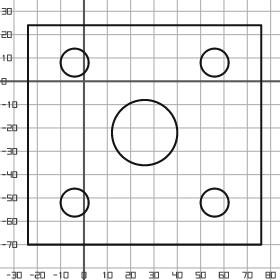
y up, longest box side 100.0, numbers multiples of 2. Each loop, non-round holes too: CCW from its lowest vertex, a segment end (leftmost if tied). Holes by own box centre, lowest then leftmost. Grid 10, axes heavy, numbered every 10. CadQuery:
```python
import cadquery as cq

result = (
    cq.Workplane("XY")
    .moveTo(-24.0, -70.0)
    .lineTo(76.0, -70.0)
    .lineTo(76.0, 24.0)
    .lineTo(-24.0, 24.0)
    .close()
    .moveTo(-4.0, -52.0)
    .circle(6.0)
    .moveTo(56.0, -52.0)
    .circle(6.0)
    .moveTo(26.0, -22.0)
    .circle(14.0)
    .moveTo(-4.0, 8.0)
    .circle(6.0)
    .moveTo(56.0, 8.0)
    .circle(6.0)
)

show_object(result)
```